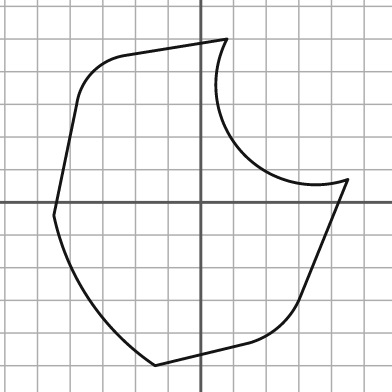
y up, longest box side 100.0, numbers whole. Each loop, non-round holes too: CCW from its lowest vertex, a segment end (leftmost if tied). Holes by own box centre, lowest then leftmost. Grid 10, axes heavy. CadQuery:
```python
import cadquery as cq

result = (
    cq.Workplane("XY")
    .moveTo(-14.0, -50.0)
    .lineTo(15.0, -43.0)
    .threePointArc((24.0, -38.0), (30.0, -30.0))
    .lineTo(45.0, 7.0)
    .threePointArc((12.0, 16.0), (8.0, 50.0))
    .lineTo(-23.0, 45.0)
    .threePointArc((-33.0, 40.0), (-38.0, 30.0))
    .lineTo(-45.0, -4.0)
    .threePointArc((-34.0, -30.0), (-14.0, -50.0))
    .close()
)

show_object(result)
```